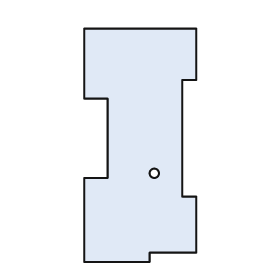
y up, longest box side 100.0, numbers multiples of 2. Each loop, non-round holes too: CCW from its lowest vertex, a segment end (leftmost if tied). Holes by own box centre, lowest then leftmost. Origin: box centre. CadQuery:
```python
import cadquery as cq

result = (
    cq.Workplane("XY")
    .moveTo(-24.0, -50.0)
    .lineTo(4.0, -50.0)
    .lineTo(4.0, -46.0)
    .lineTo(24.0, -46.0)
    .lineTo(24.0, -22.0)
    .lineTo(18.0, -22.0)
    .lineTo(18.0, 28.0)
    .lineTo(24.0, 28.0)
    .lineTo(24.0, 50.0)
    .lineTo(-24.0, 50.0)
    .lineTo(-24.0, 20.0)
    .lineTo(-14.0, 20.0)
    .lineTo(-14.0, -14.0)
    .lineTo(-24.0, -14.0)
    .close()
    .moveTo(6.0, -12.0)
    .circle(2.0)
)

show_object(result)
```